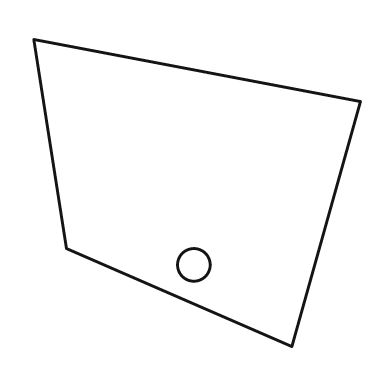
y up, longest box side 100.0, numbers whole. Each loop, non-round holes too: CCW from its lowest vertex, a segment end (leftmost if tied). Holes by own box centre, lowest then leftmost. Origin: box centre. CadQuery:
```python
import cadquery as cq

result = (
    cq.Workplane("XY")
    .moveTo(29.0, -47.0)
    .lineTo(50.0, 28.0)
    .lineTo(-50.0, 47.0)
    .lineTo(-40.0, -17.0)
    .close()
    .moveTo(-1.0, -22.0)
    .circle(5.0)
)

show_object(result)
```